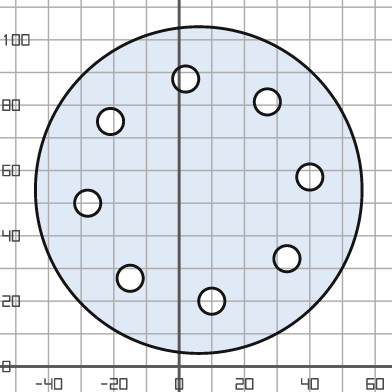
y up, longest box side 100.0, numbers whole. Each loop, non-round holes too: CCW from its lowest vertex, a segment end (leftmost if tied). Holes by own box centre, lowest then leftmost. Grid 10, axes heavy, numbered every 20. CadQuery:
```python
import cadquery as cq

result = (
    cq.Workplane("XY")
    .moveTo(6.0, 54.0)
    .circle(50.0)
    .moveTo(10.0, 20.0)
    .circle(4.0)
    .moveTo(-15.0, 27.0)
    .circle(4.0)
    .moveTo(33.0, 33.0)
    .circle(4.0)
    .moveTo(-28.0, 50.0)
    .circle(4.0)
    .moveTo(40.0, 58.0)
    .circle(4.0)
    .moveTo(-21.0, 75.0)
    .circle(4.0)
    .moveTo(27.0, 81.0)
    .circle(4.0)
    .moveTo(2.0, 88.0)
    .circle(4.0)
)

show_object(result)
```